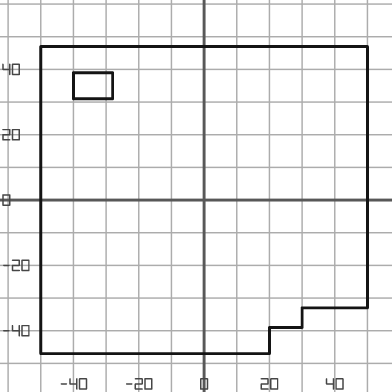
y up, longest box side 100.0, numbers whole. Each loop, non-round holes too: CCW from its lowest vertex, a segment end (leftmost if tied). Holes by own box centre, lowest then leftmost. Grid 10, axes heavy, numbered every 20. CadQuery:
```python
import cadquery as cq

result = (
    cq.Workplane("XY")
    .moveTo(-50.0, -47.0)
    .lineTo(20.0, -47.0)
    .lineTo(20.0, -39.0)
    .lineTo(30.0, -39.0)
    .lineTo(30.0, -33.0)
    .lineTo(50.0, -33.0)
    .lineTo(50.0, 47.0)
    .lineTo(-50.0, 47.0)
    .close()
    .moveTo(-40.0, 31.0)
    .lineTo(-28.0, 31.0)
    .lineTo(-28.0, 39.0)
    .lineTo(-40.0, 39.0)
    .close()
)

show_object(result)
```